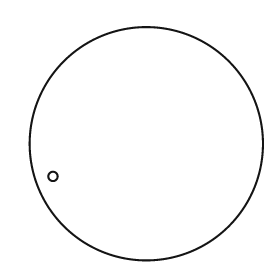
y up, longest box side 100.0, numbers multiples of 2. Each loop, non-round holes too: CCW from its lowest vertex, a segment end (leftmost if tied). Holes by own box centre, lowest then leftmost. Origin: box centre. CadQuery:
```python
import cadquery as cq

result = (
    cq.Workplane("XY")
    .moveTo(0.0, 0.0)
    .circle(50.0)
    .moveTo(-40.0, -14.0)
    .circle(2.0)
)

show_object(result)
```